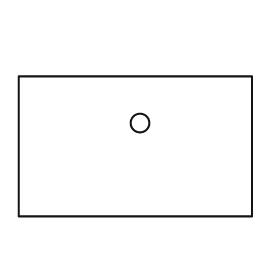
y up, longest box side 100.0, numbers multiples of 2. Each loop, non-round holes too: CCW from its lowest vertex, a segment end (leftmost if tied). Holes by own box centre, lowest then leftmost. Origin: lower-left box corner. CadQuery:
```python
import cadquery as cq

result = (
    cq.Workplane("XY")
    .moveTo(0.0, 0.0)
    .lineTo(100.0, 0.0)
    .lineTo(100.0, 60.0)
    .lineTo(0.0, 60.0)
    .close()
    .moveTo(52.0, 40.0)
    .circle(4.0)
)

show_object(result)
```